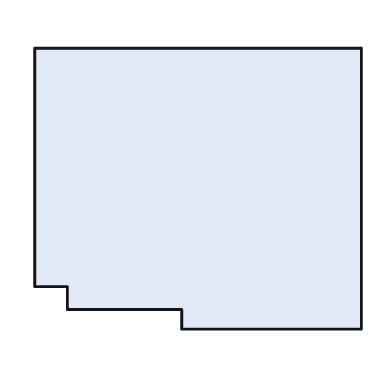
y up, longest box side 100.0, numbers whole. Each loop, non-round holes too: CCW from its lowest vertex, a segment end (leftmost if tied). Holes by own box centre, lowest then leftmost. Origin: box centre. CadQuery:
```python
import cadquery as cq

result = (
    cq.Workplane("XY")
    .moveTo(-5.0, -43.0)
    .lineTo(50.0, -43.0)
    .lineTo(50.0, 43.0)
    .lineTo(-50.0, 43.0)
    .lineTo(-50.0, -30.0)
    .lineTo(-40.0, -30.0)
    .lineTo(-40.0, -37.0)
    .lineTo(-5.0, -37.0)
    .close()
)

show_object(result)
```